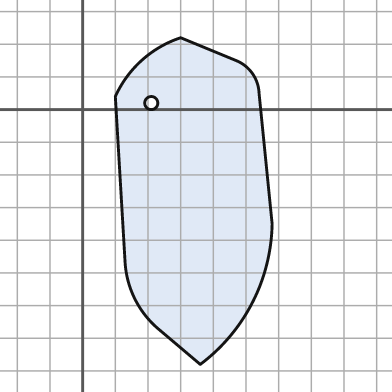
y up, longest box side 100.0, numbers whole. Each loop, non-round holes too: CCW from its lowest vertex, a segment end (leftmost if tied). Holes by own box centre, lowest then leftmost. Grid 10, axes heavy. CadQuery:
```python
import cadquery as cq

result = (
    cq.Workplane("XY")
    .moveTo(36.0, -78.0)
    .threePointArc((52.0, -59.0), (58.0, -35.0))
    .lineTo(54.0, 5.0)
    .threePointArc((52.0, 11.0), (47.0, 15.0))
    .lineTo(30.0, 22.0)
    .threePointArc((18.0, 15.0), (10.0, 4.0))
    .lineTo(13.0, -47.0)
    .threePointArc((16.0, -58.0), (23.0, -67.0))
    .close()
    .moveTo(21.0, 2.0)
    .circle(2.0)
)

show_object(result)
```